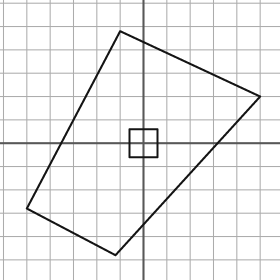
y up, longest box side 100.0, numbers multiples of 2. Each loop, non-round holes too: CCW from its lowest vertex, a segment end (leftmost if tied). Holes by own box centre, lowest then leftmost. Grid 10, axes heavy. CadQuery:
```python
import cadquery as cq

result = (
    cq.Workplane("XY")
    .moveTo(-12.0, -48.0)
    .lineTo(50.0, 20.0)
    .lineTo(-10.0, 48.0)
    .lineTo(-50.0, -28.0)
    .close()
    .moveTo(-6.0, -6.0)
    .lineTo(6.0, -6.0)
    .lineTo(6.0, 6.0)
    .lineTo(-6.0, 6.0)
    .close()
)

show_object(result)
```